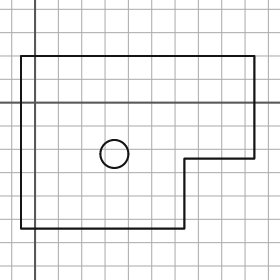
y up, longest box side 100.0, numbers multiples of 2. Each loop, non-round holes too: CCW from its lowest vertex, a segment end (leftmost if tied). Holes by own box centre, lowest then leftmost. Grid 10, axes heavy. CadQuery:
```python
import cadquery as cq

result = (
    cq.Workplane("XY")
    .moveTo(-6.0, -54.0)
    .lineTo(64.0, -54.0)
    .lineTo(64.0, -24.0)
    .lineTo(94.0, -24.0)
    .lineTo(94.0, 20.0)
    .lineTo(-6.0, 20.0)
    .close()
    .moveTo(34.0, -22.0)
    .circle(6.0)
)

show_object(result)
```